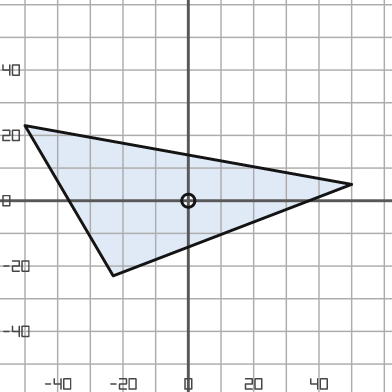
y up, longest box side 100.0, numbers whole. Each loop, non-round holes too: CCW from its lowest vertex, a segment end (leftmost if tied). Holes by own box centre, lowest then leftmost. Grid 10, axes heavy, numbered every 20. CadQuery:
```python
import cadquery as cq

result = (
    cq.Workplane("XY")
    .moveTo(-23.0, -23.0)
    .lineTo(50.0, 5.0)
    .lineTo(-50.0, 23.0)
    .close()
    .moveTo(0.0, 0.0)
    .circle(2.0)
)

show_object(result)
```